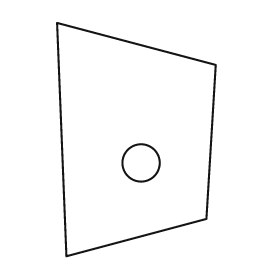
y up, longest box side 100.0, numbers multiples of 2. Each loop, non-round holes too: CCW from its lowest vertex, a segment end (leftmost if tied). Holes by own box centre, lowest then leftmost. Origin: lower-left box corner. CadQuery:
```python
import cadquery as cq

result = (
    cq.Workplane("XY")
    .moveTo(4.0, 0.0)
    .lineTo(64.0, 16.0)
    .lineTo(68.0, 82.0)
    .lineTo(0.0, 100.0)
    .close()
    .moveTo(36.0, 40.0)
    .circle(8.0)
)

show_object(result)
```